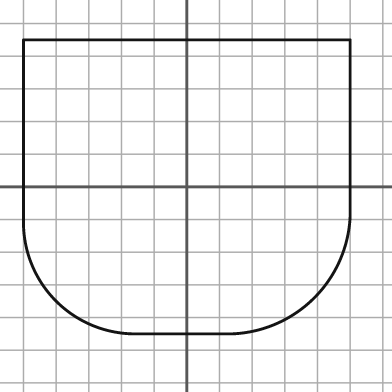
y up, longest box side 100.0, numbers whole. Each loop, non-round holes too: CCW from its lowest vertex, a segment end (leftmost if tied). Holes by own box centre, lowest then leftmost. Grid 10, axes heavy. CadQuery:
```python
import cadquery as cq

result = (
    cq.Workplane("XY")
    .moveTo(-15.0, -45.0)
    .lineTo(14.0, -45.0)
    .threePointArc((39.0, -34.0), (50.0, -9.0))
    .lineTo(50.0, 45.0)
    .lineTo(-50.0, 45.0)
    .lineTo(-50.0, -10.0)
    .threePointArc((-40.0, -35.0), (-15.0, -45.0))
    .close()
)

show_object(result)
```